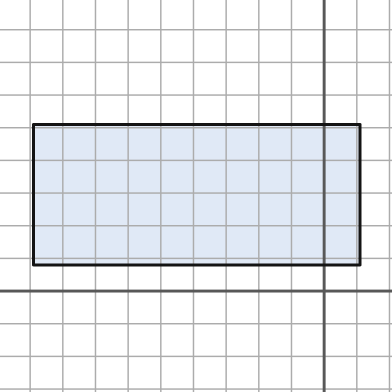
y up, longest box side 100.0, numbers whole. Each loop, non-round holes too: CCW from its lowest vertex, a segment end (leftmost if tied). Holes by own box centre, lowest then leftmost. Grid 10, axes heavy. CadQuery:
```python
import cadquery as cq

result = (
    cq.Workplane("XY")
    .moveTo(-89.0, 8.0)
    .lineTo(11.0, 8.0)
    .lineTo(11.0, 51.0)
    .lineTo(-89.0, 51.0)
    .close()
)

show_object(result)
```